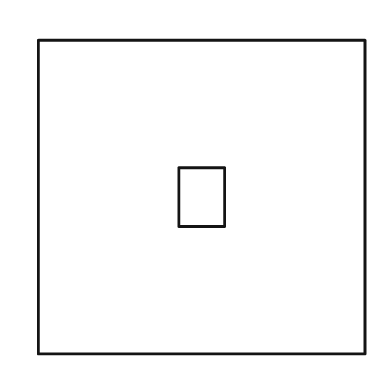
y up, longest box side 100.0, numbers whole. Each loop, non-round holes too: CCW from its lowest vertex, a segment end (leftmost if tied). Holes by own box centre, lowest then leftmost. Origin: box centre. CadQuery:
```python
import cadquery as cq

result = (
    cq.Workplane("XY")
    .moveTo(-50.0, -48.0)
    .lineTo(50.0, -48.0)
    .lineTo(50.0, 48.0)
    .lineTo(-50.0, 48.0)
    .close()
    .moveTo(-7.0, -9.0)
    .lineTo(7.0, -9.0)
    .lineTo(7.0, 9.0)
    .lineTo(-7.0, 9.0)
    .close()
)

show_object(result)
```